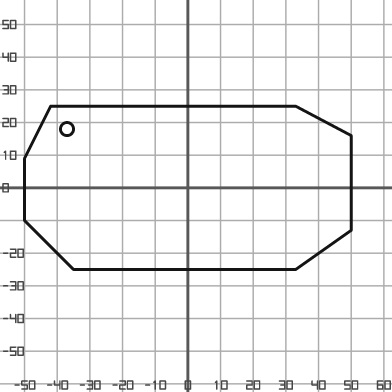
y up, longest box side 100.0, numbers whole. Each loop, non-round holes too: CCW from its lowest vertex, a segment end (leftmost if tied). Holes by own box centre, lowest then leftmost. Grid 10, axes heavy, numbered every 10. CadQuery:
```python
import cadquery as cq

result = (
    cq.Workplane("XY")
    .moveTo(-35.0, -25.0)
    .lineTo(33.0, -25.0)
    .lineTo(50.0, -13.0)
    .lineTo(50.0, 16.0)
    .lineTo(33.0, 25.0)
    .lineTo(-42.0, 25.0)
    .lineTo(-50.0, 9.0)
    .lineTo(-50.0, -10.0)
    .close()
    .moveTo(-37.0, 18.0)
    .circle(2.0)
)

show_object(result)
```